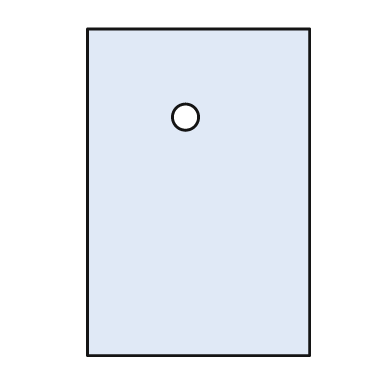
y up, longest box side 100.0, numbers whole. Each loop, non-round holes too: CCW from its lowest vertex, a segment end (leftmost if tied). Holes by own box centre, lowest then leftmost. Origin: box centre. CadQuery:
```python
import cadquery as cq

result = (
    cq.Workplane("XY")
    .moveTo(-34.0, -50.0)
    .lineTo(34.0, -50.0)
    .lineTo(34.0, 50.0)
    .lineTo(-34.0, 50.0)
    .close()
    .moveTo(-4.0, 23.0)
    .circle(4.0)
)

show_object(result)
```